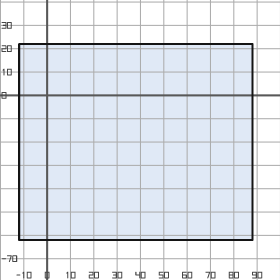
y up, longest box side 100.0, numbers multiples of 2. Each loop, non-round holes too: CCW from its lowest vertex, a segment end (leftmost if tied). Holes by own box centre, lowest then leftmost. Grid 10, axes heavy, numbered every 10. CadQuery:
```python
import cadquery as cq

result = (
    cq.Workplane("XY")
    .moveTo(-12.0, -62.0)
    .lineTo(88.0, -62.0)
    .lineTo(88.0, 22.0)
    .lineTo(-12.0, 22.0)
    .close()
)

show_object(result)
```